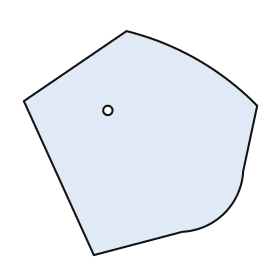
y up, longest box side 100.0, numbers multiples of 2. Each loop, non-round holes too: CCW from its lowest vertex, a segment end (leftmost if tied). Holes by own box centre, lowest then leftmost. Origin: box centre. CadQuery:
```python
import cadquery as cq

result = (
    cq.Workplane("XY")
    .moveTo(-20.0, -48.0)
    .lineTo(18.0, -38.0)
    .threePointArc((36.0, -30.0), (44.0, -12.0))
    .lineTo(50.0, 16.0)
    .threePointArc((24.0, 36.0), (-6.0, 48.0))
    .lineTo(-50.0, 18.0)
    .close()
    .moveTo(-14.0, 14.0)
    .circle(2.0)
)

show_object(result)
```